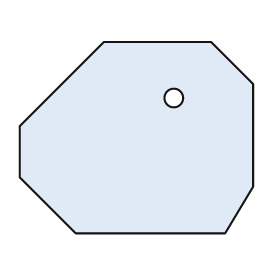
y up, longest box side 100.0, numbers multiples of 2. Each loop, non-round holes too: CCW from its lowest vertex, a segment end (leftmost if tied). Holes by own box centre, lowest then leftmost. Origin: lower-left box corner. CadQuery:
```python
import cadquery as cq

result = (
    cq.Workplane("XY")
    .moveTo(24.0, 0.0)
    .lineTo(88.0, 0.0)
    .lineTo(100.0, 20.0)
    .lineTo(100.0, 64.0)
    .lineTo(82.0, 82.0)
    .lineTo(36.0, 82.0)
    .lineTo(0.0, 46.0)
    .lineTo(0.0, 24.0)
    .close()
    .moveTo(66.0, 58.0)
    .circle(4.0)
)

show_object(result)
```